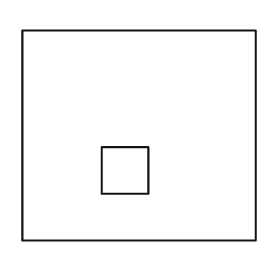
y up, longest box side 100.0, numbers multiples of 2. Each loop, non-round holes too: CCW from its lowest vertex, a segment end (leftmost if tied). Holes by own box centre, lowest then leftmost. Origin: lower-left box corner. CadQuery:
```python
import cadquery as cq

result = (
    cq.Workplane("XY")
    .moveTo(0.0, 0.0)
    .lineTo(100.0, 0.0)
    .lineTo(100.0, 90.0)
    .lineTo(0.0, 90.0)
    .close()
    .moveTo(34.0, 20.0)
    .lineTo(54.0, 20.0)
    .lineTo(54.0, 40.0)
    .lineTo(34.0, 40.0)
    .close()
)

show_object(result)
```